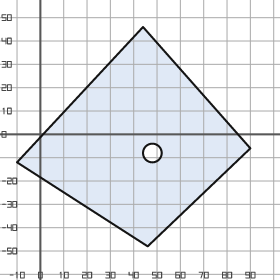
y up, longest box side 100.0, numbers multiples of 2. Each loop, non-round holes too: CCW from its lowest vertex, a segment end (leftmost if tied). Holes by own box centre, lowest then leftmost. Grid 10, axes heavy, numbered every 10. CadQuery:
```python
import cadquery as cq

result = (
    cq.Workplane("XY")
    .moveTo(46.0, -48.0)
    .lineTo(90.0, -6.0)
    .lineTo(44.0, 46.0)
    .lineTo(-10.0, -12.0)
    .close()
    .moveTo(48.0, -8.0)
    .circle(4.0)
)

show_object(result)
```